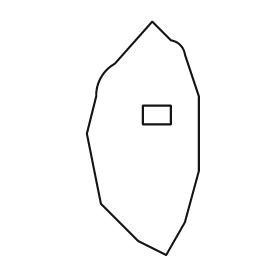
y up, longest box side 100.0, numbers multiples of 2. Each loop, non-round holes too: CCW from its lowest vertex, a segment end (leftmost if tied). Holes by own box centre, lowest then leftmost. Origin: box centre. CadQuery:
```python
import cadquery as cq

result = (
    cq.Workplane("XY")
    .moveTo(10.0, -50.0)
    .lineTo(18.0, -36.0)
    .lineTo(24.0, -14.0)
    .lineTo(24.0, 18.0)
    .lineTo(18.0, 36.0)
    .threePointArc((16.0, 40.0), (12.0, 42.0))
    .lineTo(4.0, 50.0)
    .lineTo(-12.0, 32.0)
    .threePointArc((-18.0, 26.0), (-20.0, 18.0))
    .lineTo(-24.0, 2.0)
    .lineTo(-18.0, -28.0)
    .lineTo(-2.0, -44.0)
    .close()
    .moveTo(0.0, 6.0)
    .lineTo(12.0, 6.0)
    .lineTo(12.0, 14.0)
    .lineTo(0.0, 14.0)
    .close()
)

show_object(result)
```